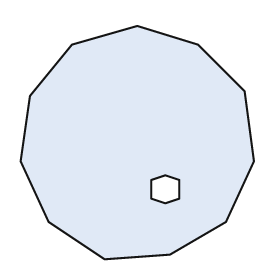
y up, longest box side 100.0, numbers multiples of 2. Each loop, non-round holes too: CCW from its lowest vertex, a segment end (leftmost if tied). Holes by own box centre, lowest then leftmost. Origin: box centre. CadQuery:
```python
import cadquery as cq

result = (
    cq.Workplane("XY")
    .moveTo(-14.0, -50.0)
    .lineTo(14.0, -48.0)
    .lineTo(38.0, -34.0)
    .lineTo(50.0, -8.0)
    .lineTo(46.0, 22.0)
    .lineTo(26.0, 42.0)
    .lineTo(0.0, 50.0)
    .lineTo(-28.0, 42.0)
    .lineTo(-46.0, 20.0)
    .lineTo(-50.0, -8.0)
    .lineTo(-38.0, -34.0)
    .close()
    .moveTo(12.0, -26.0)
    .lineTo(18.0, -24.0)
    .lineTo(18.0, -16.0)
    .lineTo(12.0, -14.0)
    .lineTo(6.0, -16.0)
    .lineTo(6.0, -24.0)
    .close()
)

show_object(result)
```